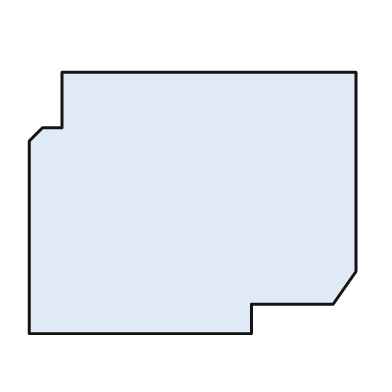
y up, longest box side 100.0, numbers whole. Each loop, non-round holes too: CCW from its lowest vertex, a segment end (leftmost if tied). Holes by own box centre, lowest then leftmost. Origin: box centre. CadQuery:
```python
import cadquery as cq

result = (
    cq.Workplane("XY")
    .moveTo(-50.0, -40.0)
    .lineTo(18.0, -40.0)
    .lineTo(18.0, -31.0)
    .lineTo(43.0, -31.0)
    .lineTo(50.0, -21.0)
    .lineTo(50.0, 40.0)
    .lineTo(-40.0, 40.0)
    .lineTo(-40.0, 23.0)
    .lineTo(-46.0, 23.0)
    .lineTo(-50.0, 19.0)
    .close()
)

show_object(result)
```